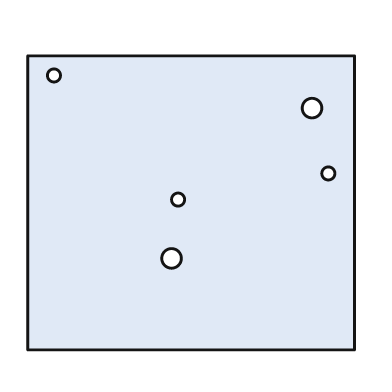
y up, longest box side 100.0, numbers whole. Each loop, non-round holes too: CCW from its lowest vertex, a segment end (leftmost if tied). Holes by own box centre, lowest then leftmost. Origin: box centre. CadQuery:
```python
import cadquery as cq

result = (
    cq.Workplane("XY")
    .moveTo(-50.0, -45.0)
    .lineTo(50.0, -45.0)
    .lineTo(50.0, 45.0)
    .lineTo(-50.0, 45.0)
    .close()
    .moveTo(-6.0, -17.0)
    .circle(3.0)
    .moveTo(-4.0, 1.0)
    .circle(2.0)
    .moveTo(42.0, 9.0)
    .circle(2.0)
    .moveTo(37.0, 29.0)
    .circle(3.0)
    .moveTo(-42.0, 39.0)
    .circle(2.0)
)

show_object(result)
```